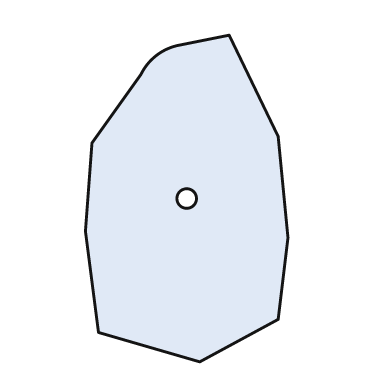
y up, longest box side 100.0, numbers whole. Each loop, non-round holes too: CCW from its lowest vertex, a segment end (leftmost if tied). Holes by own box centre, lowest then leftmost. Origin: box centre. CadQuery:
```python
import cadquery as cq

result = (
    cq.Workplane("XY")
    .moveTo(4.0, -50.0)
    .lineTo(28.0, -37.0)
    .lineTo(31.0, -12.0)
    .lineTo(28.0, 19.0)
    .lineTo(13.0, 50.0)
    .lineTo(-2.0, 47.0)
    .threePointArc((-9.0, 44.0), (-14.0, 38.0))
    .lineTo(-29.0, 17.0)
    .lineTo(-31.0, -10.0)
    .lineTo(-27.0, -41.0)
    .close()
    .moveTo(0.0, 0.0)
    .circle(3.0)
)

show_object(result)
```